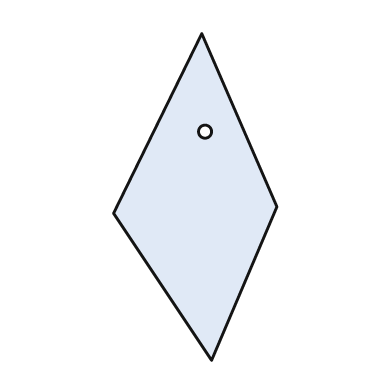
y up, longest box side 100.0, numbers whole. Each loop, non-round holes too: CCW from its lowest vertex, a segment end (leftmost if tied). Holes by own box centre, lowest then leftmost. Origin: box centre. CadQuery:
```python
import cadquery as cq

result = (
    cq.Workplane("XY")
    .moveTo(5.0, -50.0)
    .lineTo(25.0, -3.0)
    .lineTo(2.0, 50.0)
    .lineTo(-25.0, -5.0)
    .close()
    .moveTo(3.0, 20.0)
    .circle(2.0)
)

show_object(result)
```